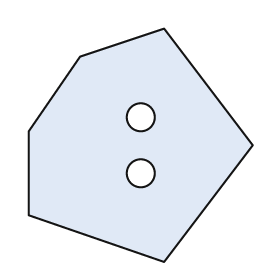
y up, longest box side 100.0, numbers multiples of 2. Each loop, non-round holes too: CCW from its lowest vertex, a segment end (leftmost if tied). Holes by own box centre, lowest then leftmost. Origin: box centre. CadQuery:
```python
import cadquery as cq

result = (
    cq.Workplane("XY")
    .moveTo(10.0, -50.0)
    .lineTo(48.0, 0.0)
    .lineTo(10.0, 50.0)
    .lineTo(-26.0, 38.0)
    .lineTo(-48.0, 6.0)
    .lineTo(-48.0, -30.0)
    .close()
    .moveTo(0.0, -12.0)
    .circle(6.0)
    .moveTo(0.0, 12.0)
    .circle(6.0)
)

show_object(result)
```